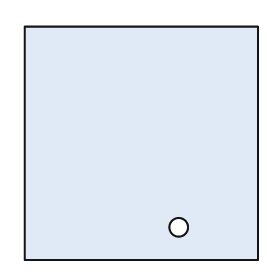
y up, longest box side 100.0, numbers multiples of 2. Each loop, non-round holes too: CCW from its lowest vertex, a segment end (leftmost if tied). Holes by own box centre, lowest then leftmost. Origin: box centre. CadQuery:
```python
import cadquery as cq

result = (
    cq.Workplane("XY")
    .moveTo(-50.0, -50.0)
    .lineTo(50.0, -50.0)
    .lineTo(50.0, 50.0)
    .lineTo(-50.0, 50.0)
    .close()
    .moveTo(16.0, -36.0)
    .circle(4.0)
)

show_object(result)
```